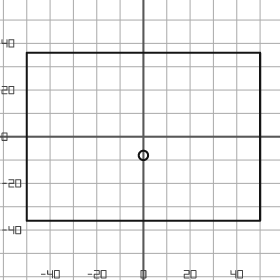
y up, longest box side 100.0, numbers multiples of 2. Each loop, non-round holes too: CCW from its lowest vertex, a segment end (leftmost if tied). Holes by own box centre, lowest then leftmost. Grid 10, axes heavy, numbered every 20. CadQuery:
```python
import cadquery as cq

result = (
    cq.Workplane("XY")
    .moveTo(-50.0, -36.0)
    .lineTo(50.0, -36.0)
    .lineTo(50.0, 36.0)
    .lineTo(-50.0, 36.0)
    .close()
    .moveTo(0.0, -8.0)
    .circle(2.0)
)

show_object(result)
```